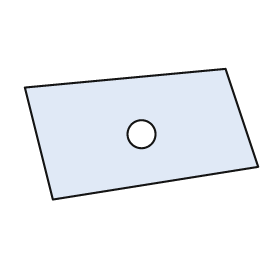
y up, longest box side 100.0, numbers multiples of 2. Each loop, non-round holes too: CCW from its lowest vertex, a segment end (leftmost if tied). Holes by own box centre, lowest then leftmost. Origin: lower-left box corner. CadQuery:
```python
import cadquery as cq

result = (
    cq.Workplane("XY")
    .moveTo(12.0, 0.0)
    .lineTo(100.0, 14.0)
    .lineTo(86.0, 56.0)
    .lineTo(0.0, 48.0)
    .close()
    .moveTo(50.0, 28.0)
    .circle(6.0)
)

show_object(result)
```